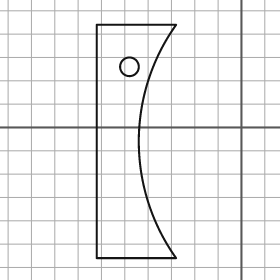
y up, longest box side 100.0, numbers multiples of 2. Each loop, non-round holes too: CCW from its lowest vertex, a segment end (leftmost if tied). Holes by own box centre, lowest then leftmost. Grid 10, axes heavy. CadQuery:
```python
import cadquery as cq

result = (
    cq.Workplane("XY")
    .moveTo(-62.0, -56.0)
    .lineTo(-28.0, -56.0)
    .threePointArc((-44.0, -6.0), (-28.0, 44.0))
    .lineTo(-62.0, 44.0)
    .close()
    .moveTo(-48.0, 26.0)
    .circle(4.0)
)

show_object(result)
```